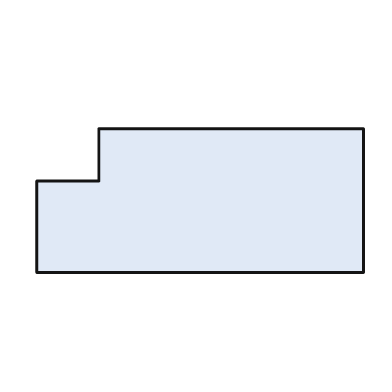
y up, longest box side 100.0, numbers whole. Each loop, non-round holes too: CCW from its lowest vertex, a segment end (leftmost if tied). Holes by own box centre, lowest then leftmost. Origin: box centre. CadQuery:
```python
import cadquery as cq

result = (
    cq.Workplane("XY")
    .moveTo(-50.0, -22.0)
    .lineTo(50.0, -22.0)
    .lineTo(50.0, 22.0)
    .lineTo(-31.0, 22.0)
    .lineTo(-31.0, 6.0)
    .lineTo(-50.0, 6.0)
    .close()
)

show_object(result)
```